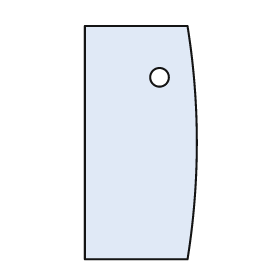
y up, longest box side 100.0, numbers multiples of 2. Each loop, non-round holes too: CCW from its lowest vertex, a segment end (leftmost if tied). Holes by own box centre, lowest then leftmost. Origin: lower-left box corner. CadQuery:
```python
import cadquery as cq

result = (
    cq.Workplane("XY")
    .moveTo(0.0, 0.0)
    .lineTo(44.0, 0.0)
    .threePointArc((48.0, 50.0), (44.0, 100.0))
    .lineTo(0.0, 100.0)
    .close()
    .moveTo(32.0, 78.0)
    .circle(4.0)
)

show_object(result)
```